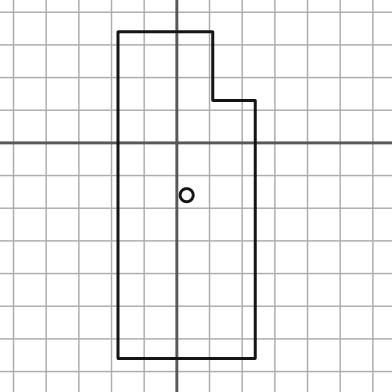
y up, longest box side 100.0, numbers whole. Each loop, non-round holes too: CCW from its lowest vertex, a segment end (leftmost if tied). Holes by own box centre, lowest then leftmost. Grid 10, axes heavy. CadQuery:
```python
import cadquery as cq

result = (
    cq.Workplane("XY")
    .moveTo(-18.0, -66.0)
    .lineTo(24.0, -66.0)
    .lineTo(24.0, 13.0)
    .lineTo(11.0, 13.0)
    .lineTo(11.0, 34.0)
    .lineTo(-18.0, 34.0)
    .close()
    .moveTo(3.0, -16.0)
    .circle(2.0)
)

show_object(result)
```